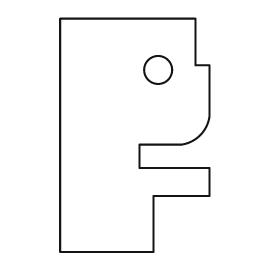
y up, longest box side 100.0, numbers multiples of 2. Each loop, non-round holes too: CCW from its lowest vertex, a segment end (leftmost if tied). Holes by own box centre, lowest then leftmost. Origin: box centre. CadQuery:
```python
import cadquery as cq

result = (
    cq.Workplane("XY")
    .moveTo(-32.0, -50.0)
    .lineTo(8.0, -50.0)
    .lineTo(8.0, -26.0)
    .lineTo(32.0, -26.0)
    .lineTo(32.0, -14.0)
    .lineTo(2.0, -14.0)
    .lineTo(2.0, -4.0)
    .lineTo(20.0, -4.0)
    .threePointArc((28.0, 0.0), (32.0, 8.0))
    .lineTo(32.0, 30.0)
    .lineTo(26.0, 30.0)
    .lineTo(26.0, 50.0)
    .lineTo(-32.0, 50.0)
    .close()
    .moveTo(10.0, 28.0)
    .circle(6.0)
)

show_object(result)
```